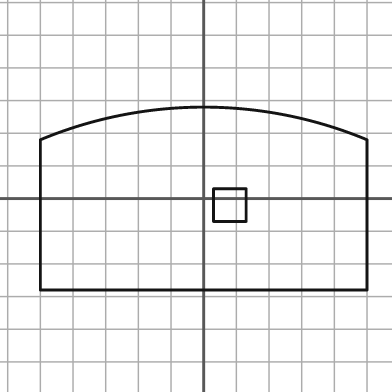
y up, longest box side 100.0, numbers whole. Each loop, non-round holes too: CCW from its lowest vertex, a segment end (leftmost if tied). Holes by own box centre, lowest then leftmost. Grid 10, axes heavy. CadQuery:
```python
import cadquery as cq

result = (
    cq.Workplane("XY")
    .moveTo(-50.0, -28.0)
    .lineTo(50.0, -28.0)
    .lineTo(50.0, 18.0)
    .threePointArc((0.0, 28.0), (-50.0, 18.0))
    .close()
    .moveTo(3.0, -7.0)
    .lineTo(13.0, -7.0)
    .lineTo(13.0, 3.0)
    .lineTo(3.0, 3.0)
    .close()
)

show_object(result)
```